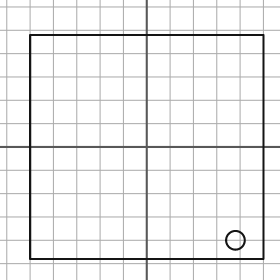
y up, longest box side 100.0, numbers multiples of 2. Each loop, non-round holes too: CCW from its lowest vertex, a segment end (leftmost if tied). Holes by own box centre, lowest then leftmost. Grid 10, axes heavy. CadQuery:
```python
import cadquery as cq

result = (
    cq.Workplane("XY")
    .moveTo(-50.0, -48.0)
    .lineTo(50.0, -48.0)
    .lineTo(50.0, 48.0)
    .lineTo(-50.0, 48.0)
    .close()
    .moveTo(38.0, -40.0)
    .circle(4.0)
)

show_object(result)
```